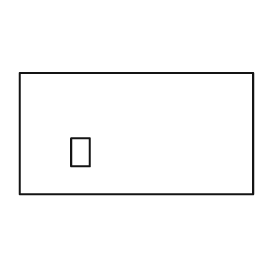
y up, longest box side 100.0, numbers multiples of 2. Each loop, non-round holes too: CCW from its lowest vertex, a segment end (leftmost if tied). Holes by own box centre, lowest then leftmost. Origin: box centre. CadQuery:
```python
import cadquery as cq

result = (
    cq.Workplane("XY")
    .moveTo(-50.0, -26.0)
    .lineTo(50.0, -26.0)
    .lineTo(50.0, 26.0)
    .lineTo(-50.0, 26.0)
    .close()
    .moveTo(-28.0, -14.0)
    .lineTo(-20.0, -14.0)
    .lineTo(-20.0, -2.0)
    .lineTo(-28.0, -2.0)
    .close()
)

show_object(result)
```